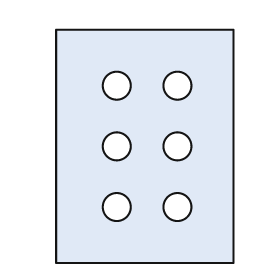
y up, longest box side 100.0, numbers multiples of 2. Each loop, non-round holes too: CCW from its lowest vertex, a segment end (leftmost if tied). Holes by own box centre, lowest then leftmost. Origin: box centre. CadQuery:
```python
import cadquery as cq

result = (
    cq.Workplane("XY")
    .moveTo(-38.0, -50.0)
    .lineTo(38.0, -50.0)
    .lineTo(38.0, 50.0)
    .lineTo(-38.0, 50.0)
    .close()
    .moveTo(-12.0, -26.0)
    .circle(6.0)
    .moveTo(14.0, -26.0)
    .circle(6.0)
    .moveTo(-12.0, 0.0)
    .circle(6.0)
    .moveTo(14.0, 0.0)
    .circle(6.0)
    .moveTo(-12.0, 26.0)
    .circle(6.0)
    .moveTo(14.0, 26.0)
    .circle(6.0)
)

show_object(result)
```